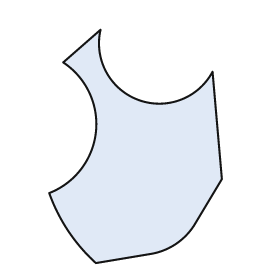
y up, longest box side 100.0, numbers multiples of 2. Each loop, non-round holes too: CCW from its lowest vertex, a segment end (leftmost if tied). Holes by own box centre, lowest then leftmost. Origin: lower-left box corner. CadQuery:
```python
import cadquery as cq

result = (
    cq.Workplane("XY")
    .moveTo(20.0, 0.0)
    .lineTo(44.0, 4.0)
    .threePointArc((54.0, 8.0), (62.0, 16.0))
    .lineTo(74.0, 36.0)
    .lineTo(70.0, 82.0)
    .threePointArc((38.0, 70.0), (22.0, 100.0))
    .lineTo(6.0, 86.0)
    .threePointArc((20.0, 56.0), (0.0, 30.0))
    .threePointArc((8.0, 14.0), (20.0, 0.0))
    .close()
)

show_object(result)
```